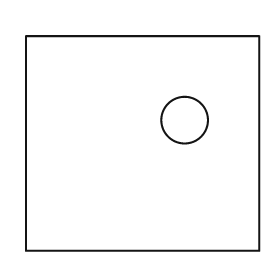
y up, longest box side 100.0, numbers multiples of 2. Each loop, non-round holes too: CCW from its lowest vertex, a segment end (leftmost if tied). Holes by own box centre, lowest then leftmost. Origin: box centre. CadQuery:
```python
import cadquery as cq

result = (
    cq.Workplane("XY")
    .moveTo(-50.0, -46.0)
    .lineTo(50.0, -46.0)
    .lineTo(50.0, 46.0)
    .lineTo(-50.0, 46.0)
    .close()
    .moveTo(18.0, 10.0)
    .circle(10.0)
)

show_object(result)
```